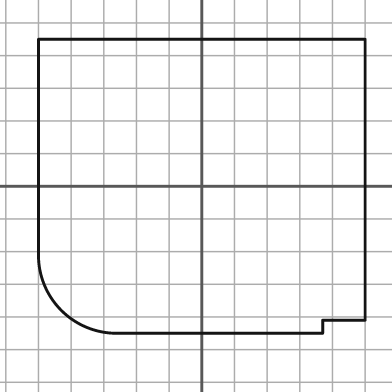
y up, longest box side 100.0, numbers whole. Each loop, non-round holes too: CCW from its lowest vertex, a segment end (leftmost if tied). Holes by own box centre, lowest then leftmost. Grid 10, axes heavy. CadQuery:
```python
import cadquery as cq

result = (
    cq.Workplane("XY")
    .moveTo(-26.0, -45.0)
    .lineTo(37.0, -45.0)
    .lineTo(37.0, -41.0)
    .lineTo(50.0, -41.0)
    .lineTo(50.0, 45.0)
    .lineTo(-50.0, 45.0)
    .lineTo(-50.0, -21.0)
    .threePointArc((-43.0, -38.0), (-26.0, -45.0))
    .close()
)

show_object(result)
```